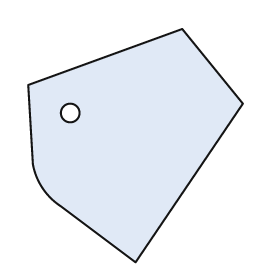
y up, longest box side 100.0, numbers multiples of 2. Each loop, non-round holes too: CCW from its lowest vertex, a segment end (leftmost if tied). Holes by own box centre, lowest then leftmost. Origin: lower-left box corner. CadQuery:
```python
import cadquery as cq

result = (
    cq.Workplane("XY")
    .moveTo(46.0, 0.0)
    .lineTo(92.0, 68.0)
    .lineTo(66.0, 100.0)
    .lineTo(0.0, 76.0)
    .lineTo(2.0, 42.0)
    .threePointArc((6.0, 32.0), (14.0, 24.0))
    .close()
    .moveTo(18.0, 64.0)
    .circle(4.0)
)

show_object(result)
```